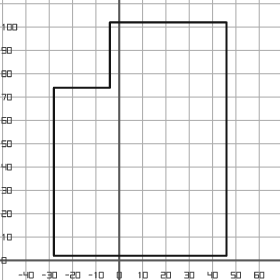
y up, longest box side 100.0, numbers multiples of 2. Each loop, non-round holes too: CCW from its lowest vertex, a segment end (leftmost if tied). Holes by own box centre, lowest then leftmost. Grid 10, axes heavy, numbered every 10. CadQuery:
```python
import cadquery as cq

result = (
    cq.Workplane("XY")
    .moveTo(-28.0, 2.0)
    .lineTo(46.0, 2.0)
    .lineTo(46.0, 102.0)
    .lineTo(-4.0, 102.0)
    .lineTo(-4.0, 74.0)
    .lineTo(-28.0, 74.0)
    .close()
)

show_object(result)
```